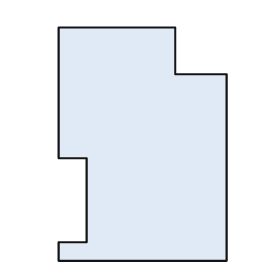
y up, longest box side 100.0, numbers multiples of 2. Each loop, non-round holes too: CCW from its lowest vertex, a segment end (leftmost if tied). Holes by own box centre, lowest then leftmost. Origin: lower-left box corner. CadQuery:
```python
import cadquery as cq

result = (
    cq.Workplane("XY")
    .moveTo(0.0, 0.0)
    .lineTo(72.0, 0.0)
    .lineTo(72.0, 80.0)
    .lineTo(50.0, 80.0)
    .lineTo(50.0, 100.0)
    .lineTo(0.0, 100.0)
    .lineTo(0.0, 44.0)
    .lineTo(12.0, 44.0)
    .lineTo(12.0, 8.0)
    .lineTo(0.0, 8.0)
    .close()
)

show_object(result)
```